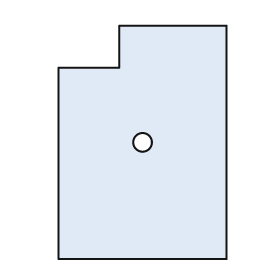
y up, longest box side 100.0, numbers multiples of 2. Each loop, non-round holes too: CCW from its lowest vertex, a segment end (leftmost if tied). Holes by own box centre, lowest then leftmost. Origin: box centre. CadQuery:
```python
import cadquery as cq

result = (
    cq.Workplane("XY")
    .moveTo(-36.0, -50.0)
    .lineTo(36.0, -50.0)
    .lineTo(36.0, 50.0)
    .lineTo(-10.0, 50.0)
    .lineTo(-10.0, 32.0)
    .lineTo(-36.0, 32.0)
    .close()
    .moveTo(0.0, 0.0)
    .circle(4.0)
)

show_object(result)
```